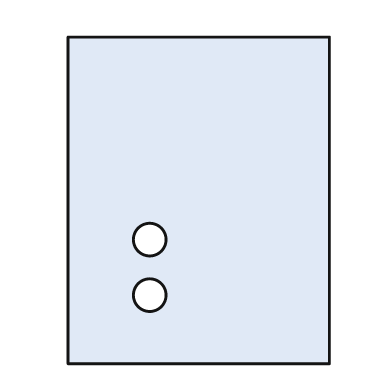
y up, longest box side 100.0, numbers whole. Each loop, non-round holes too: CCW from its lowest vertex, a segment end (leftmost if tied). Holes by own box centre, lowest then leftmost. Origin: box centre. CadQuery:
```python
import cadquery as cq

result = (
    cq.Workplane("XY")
    .moveTo(-40.0, -50.0)
    .lineTo(40.0, -50.0)
    .lineTo(40.0, 50.0)
    .lineTo(-40.0, 50.0)
    .close()
    .moveTo(-15.0, -29.0)
    .circle(5.0)
    .moveTo(-15.0, -12.0)
    .circle(5.0)
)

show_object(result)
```